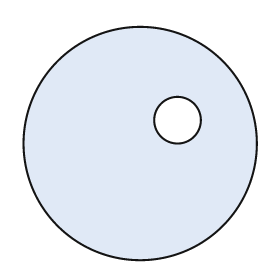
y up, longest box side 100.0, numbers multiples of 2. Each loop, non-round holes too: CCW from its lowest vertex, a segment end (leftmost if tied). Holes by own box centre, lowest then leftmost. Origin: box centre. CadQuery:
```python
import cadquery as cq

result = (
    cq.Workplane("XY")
    .moveTo(0.0, 0.0)
    .circle(50.0)
    .moveTo(16.0, 10.0)
    .circle(10.0)
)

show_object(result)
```